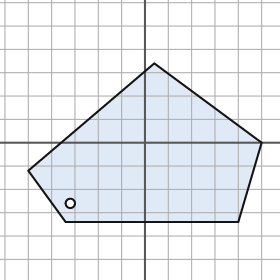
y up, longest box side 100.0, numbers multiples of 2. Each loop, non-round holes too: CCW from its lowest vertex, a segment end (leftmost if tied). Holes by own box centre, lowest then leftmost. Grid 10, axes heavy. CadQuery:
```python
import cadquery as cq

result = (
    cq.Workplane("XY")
    .moveTo(-34.0, -34.0)
    .lineTo(40.0, -34.0)
    .lineTo(50.0, 0.0)
    .lineTo(4.0, 34.0)
    .lineTo(-50.0, -12.0)
    .close()
    .moveTo(-32.0, -26.0)
    .circle(2.0)
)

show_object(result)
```